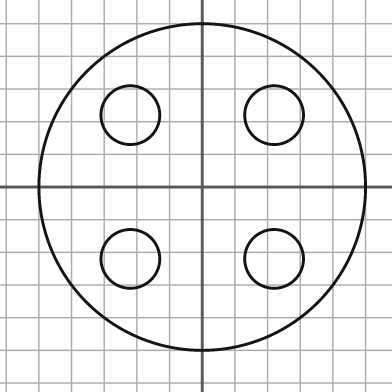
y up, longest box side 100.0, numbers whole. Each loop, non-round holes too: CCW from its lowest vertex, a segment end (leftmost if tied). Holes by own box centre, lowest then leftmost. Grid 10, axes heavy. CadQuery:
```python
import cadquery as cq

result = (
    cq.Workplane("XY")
    .moveTo(0.0, 0.0)
    .circle(50.0)
    .moveTo(-22.0, -22.0)
    .circle(9.0)
    .moveTo(22.0, -22.0)
    .circle(9.0)
    .moveTo(-22.0, 22.0)
    .circle(9.0)
    .moveTo(22.0, 22.0)
    .circle(9.0)
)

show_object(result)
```